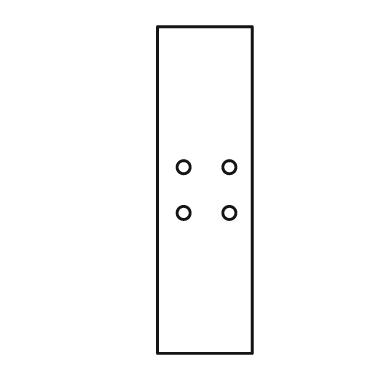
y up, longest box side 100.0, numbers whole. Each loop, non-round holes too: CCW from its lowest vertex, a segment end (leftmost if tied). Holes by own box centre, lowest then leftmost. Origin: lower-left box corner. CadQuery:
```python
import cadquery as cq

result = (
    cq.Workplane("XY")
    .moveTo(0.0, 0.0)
    .lineTo(29.0, 0.0)
    .lineTo(29.0, 100.0)
    .lineTo(0.0, 100.0)
    .close()
    .moveTo(8.0, 43.0)
    .circle(2.0)
    .moveTo(22.0, 43.0)
    .circle(2.0)
    .moveTo(8.0, 57.0)
    .circle(2.0)
    .moveTo(22.0, 57.0)
    .circle(2.0)
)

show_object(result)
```